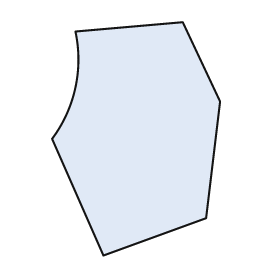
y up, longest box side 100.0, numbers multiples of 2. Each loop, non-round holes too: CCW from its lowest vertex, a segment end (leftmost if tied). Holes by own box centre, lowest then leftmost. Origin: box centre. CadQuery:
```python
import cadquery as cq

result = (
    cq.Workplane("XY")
    .moveTo(-14.0, -50.0)
    .lineTo(30.0, -34.0)
    .lineTo(36.0, 16.0)
    .lineTo(20.0, 50.0)
    .lineTo(-26.0, 46.0)
    .threePointArc((-26.0, 22.0), (-36.0, 0.0))
    .close()
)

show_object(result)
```